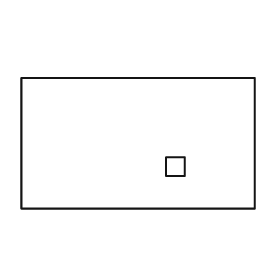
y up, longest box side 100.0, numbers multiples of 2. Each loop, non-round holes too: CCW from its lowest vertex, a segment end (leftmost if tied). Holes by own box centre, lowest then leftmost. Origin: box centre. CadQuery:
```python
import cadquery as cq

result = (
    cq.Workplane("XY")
    .moveTo(-50.0, -28.0)
    .lineTo(50.0, -28.0)
    .lineTo(50.0, 28.0)
    .lineTo(-50.0, 28.0)
    .close()
    .moveTo(12.0, -14.0)
    .lineTo(20.0, -14.0)
    .lineTo(20.0, -6.0)
    .lineTo(12.0, -6.0)
    .close()
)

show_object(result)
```